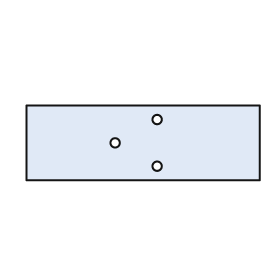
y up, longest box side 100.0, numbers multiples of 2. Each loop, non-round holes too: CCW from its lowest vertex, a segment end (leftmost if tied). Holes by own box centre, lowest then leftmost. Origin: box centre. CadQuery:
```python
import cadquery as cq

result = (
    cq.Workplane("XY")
    .moveTo(-50.0, -16.0)
    .lineTo(50.0, -16.0)
    .lineTo(50.0, 16.0)
    .lineTo(-50.0, 16.0)
    .close()
    .moveTo(6.0, -10.0)
    .circle(2.0)
    .moveTo(-12.0, 0.0)
    .circle(2.0)
    .moveTo(6.0, 10.0)
    .circle(2.0)
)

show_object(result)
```